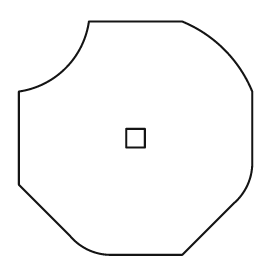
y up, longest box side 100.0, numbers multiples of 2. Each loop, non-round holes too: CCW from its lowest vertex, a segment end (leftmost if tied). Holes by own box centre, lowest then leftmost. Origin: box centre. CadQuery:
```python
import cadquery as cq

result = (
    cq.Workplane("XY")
    .moveTo(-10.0, -50.0)
    .lineTo(20.0, -50.0)
    .lineTo(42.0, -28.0)
    .threePointArc((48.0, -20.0), (50.0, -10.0))
    .lineTo(50.0, 20.0)
    .threePointArc((38.0, 38.0), (20.0, 50.0))
    .lineTo(-20.0, 50.0)
    .threePointArc((-30.0, 30.0), (-50.0, 20.0))
    .lineTo(-50.0, -20.0)
    .lineTo(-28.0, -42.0)
    .threePointArc((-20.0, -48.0), (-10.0, -50.0))
    .close()
    .moveTo(-4.0, -4.0)
    .lineTo(4.0, -4.0)
    .lineTo(4.0, 4.0)
    .lineTo(-4.0, 4.0)
    .close()
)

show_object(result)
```